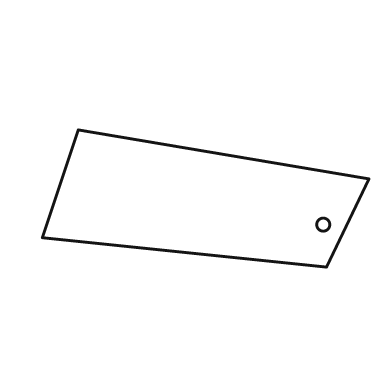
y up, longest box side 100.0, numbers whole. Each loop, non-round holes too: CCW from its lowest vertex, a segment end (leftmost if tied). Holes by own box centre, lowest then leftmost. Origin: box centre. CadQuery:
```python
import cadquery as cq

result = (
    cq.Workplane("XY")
    .moveTo(37.0, -21.0)
    .lineTo(50.0, 6.0)
    .lineTo(-39.0, 21.0)
    .lineTo(-50.0, -12.0)
    .close()
    .moveTo(36.0, -8.0)
    .circle(2.0)
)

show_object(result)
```